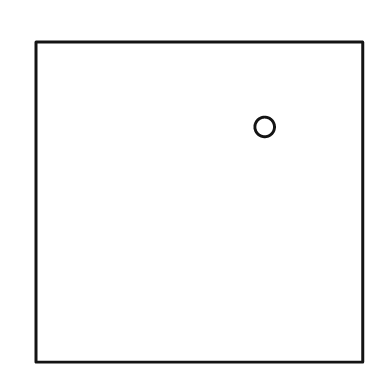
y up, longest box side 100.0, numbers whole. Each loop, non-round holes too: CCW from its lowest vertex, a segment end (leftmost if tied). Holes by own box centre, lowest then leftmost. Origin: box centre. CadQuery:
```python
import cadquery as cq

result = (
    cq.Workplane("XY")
    .moveTo(-50.0, -49.0)
    .lineTo(50.0, -49.0)
    .lineTo(50.0, 49.0)
    .lineTo(-50.0, 49.0)
    .close()
    .moveTo(20.0, 23.0)
    .circle(3.0)
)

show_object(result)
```